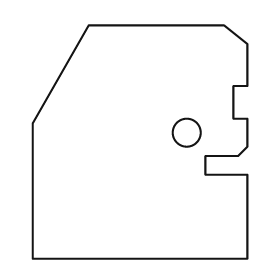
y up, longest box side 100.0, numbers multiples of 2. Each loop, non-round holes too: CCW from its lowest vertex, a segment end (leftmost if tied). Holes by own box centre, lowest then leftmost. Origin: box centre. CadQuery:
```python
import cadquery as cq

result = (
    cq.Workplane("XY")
    .moveTo(-46.0, -50.0)
    .lineTo(46.0, -50.0)
    .lineTo(46.0, -14.0)
    .lineTo(28.0, -14.0)
    .lineTo(28.0, -6.0)
    .lineTo(42.0, -6.0)
    .lineTo(46.0, -2.0)
    .lineTo(46.0, 10.0)
    .lineTo(40.0, 10.0)
    .lineTo(40.0, 24.0)
    .lineTo(46.0, 24.0)
    .lineTo(46.0, 42.0)
    .lineTo(36.0, 50.0)
    .lineTo(-22.0, 50.0)
    .lineTo(-46.0, 8.0)
    .close()
    .moveTo(20.0, 4.0)
    .circle(6.0)
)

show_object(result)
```